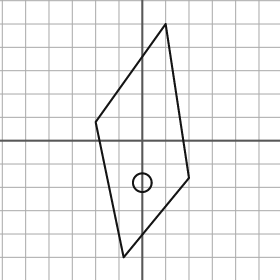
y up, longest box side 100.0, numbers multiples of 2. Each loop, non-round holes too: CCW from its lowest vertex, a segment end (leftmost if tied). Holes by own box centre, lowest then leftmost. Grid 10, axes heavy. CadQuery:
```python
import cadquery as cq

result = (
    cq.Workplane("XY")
    .moveTo(-8.0, -50.0)
    .lineTo(20.0, -16.0)
    .lineTo(10.0, 50.0)
    .lineTo(-20.0, 8.0)
    .close()
    .moveTo(0.0, -18.0)
    .circle(4.0)
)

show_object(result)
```